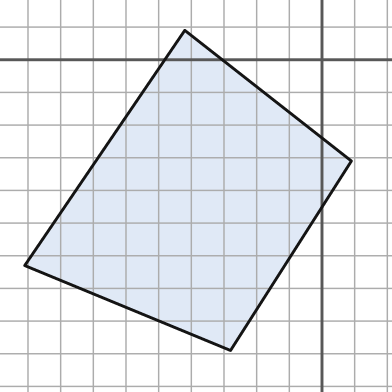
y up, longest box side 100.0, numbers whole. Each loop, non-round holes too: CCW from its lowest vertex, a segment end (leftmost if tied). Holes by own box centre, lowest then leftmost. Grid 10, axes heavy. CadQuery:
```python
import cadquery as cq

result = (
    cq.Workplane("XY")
    .moveTo(-28.0, -89.0)
    .lineTo(9.0, -31.0)
    .lineTo(-42.0, 9.0)
    .lineTo(-91.0, -63.0)
    .close()
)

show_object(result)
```